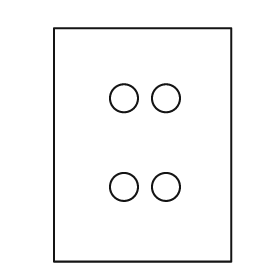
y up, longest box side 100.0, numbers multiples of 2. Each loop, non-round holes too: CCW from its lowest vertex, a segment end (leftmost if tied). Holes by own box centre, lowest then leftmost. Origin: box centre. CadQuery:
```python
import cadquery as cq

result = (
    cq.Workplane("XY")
    .moveTo(-38.0, -50.0)
    .lineTo(38.0, -50.0)
    .lineTo(38.0, 50.0)
    .lineTo(-38.0, 50.0)
    .close()
    .moveTo(-8.0, -18.0)
    .circle(6.0)
    .moveTo(10.0, -18.0)
    .circle(6.0)
    .moveTo(-8.0, 20.0)
    .circle(6.0)
    .moveTo(10.0, 20.0)
    .circle(6.0)
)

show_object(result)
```